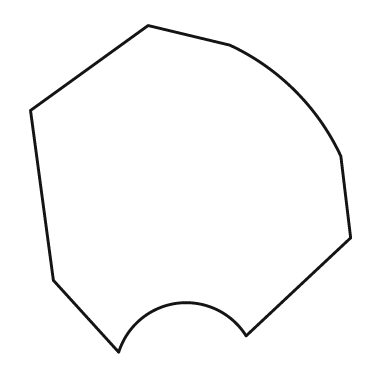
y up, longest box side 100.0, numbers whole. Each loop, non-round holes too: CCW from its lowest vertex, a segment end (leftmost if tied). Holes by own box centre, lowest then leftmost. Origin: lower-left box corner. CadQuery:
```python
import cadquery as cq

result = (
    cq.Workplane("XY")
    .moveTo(27.0, 0.0)
    .threePointArc((45.0, 15.0), (66.0, 5.0))
    .lineTo(98.0, 35.0)
    .lineTo(95.0, 60.0)
    .threePointArc((81.0, 80.0), (61.0, 94.0))
    .lineTo(36.0, 100.0)
    .lineTo(0.0, 74.0)
    .lineTo(7.0, 22.0)
    .close()
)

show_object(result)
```